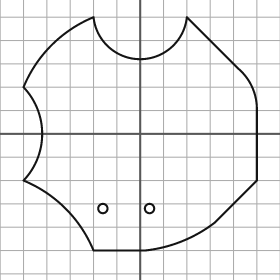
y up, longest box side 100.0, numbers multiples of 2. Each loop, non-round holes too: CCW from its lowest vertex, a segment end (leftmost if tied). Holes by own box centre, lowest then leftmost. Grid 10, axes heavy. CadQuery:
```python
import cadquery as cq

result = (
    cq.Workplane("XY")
    .moveTo(-20.0, -50.0)
    .lineTo(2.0, -50.0)
    .threePointArc((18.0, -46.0), (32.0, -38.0))
    .lineTo(50.0, -20.0)
    .lineTo(50.0, 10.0)
    .threePointArc((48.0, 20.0), (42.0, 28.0))
    .lineTo(20.0, 50.0)
    .threePointArc((0.0, 32.0), (-20.0, 50.0))
    .threePointArc((-38.0, 38.0), (-50.0, 20.0))
    .threePointArc((-42.0, 0.0), (-50.0, -20.0))
    .threePointArc((-32.0, -32.0), (-20.0, -50.0))
    .close()
    .moveTo(-16.0, -32.0)
    .circle(2.0)
    .moveTo(4.0, -32.0)
    .circle(2.0)
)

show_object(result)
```